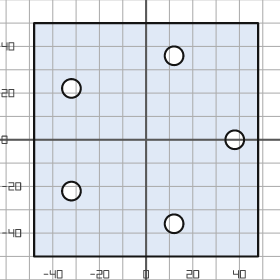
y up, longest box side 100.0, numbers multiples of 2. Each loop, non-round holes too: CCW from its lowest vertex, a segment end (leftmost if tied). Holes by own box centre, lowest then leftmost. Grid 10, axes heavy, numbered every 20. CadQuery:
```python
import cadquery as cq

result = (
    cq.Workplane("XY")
    .moveTo(-48.0, -50.0)
    .lineTo(48.0, -50.0)
    .lineTo(48.0, 50.0)
    .lineTo(-48.0, 50.0)
    .close()
    .moveTo(12.0, -36.0)
    .circle(4.0)
    .moveTo(-32.0, -22.0)
    .circle(4.0)
    .moveTo(38.0, 0.0)
    .circle(4.0)
    .moveTo(-32.0, 22.0)
    .circle(4.0)
    .moveTo(12.0, 36.0)
    .circle(4.0)
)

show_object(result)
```